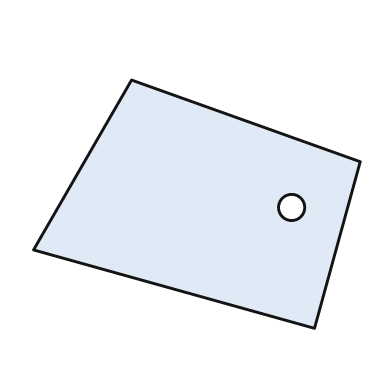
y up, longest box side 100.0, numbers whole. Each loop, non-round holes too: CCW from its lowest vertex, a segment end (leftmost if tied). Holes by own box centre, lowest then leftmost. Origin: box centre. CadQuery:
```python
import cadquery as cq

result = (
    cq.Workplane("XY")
    .moveTo(36.0, -38.0)
    .lineTo(50.0, 13.0)
    .lineTo(-20.0, 38.0)
    .lineTo(-50.0, -14.0)
    .close()
    .moveTo(29.0, -1.0)
    .circle(4.0)
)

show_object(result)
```